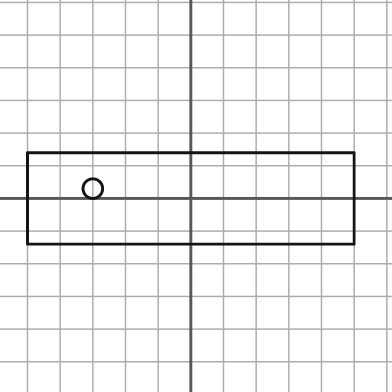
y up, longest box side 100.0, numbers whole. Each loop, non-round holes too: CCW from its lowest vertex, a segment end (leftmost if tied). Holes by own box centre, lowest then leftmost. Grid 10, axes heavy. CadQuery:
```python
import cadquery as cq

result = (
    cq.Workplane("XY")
    .moveTo(-50.0, -14.0)
    .lineTo(50.0, -14.0)
    .lineTo(50.0, 14.0)
    .lineTo(-50.0, 14.0)
    .close()
    .moveTo(-30.0, 3.0)
    .circle(3.0)
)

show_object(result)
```